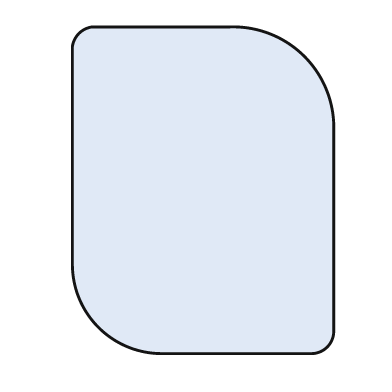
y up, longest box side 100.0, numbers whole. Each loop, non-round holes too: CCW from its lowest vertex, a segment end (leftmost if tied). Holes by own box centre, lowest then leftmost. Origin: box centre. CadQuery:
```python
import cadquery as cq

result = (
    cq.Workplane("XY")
    .moveTo(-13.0, -50.0)
    .lineTo(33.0, -50.0)
    .threePointArc((38.0, -48.0), (40.0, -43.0))
    .lineTo(40.0, 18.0)
    .threePointArc((31.0, 41.0), (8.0, 50.0))
    .lineTo(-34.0, 50.0)
    .threePointArc((-38.0, 48.0), (-40.0, 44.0))
    .lineTo(-40.0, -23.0)
    .threePointArc((-32.0, -42.0), (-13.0, -50.0))
    .close()
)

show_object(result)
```